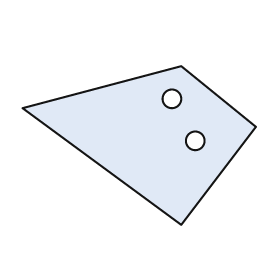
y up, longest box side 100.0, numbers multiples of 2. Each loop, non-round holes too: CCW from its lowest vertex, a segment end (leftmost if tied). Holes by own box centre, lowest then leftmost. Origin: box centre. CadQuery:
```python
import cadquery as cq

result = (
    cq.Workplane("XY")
    .moveTo(18.0, -34.0)
    .lineTo(50.0, 8.0)
    .lineTo(18.0, 34.0)
    .lineTo(-50.0, 16.0)
    .close()
    .moveTo(24.0, 2.0)
    .circle(4.0)
    .moveTo(14.0, 20.0)
    .circle(4.0)
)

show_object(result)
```